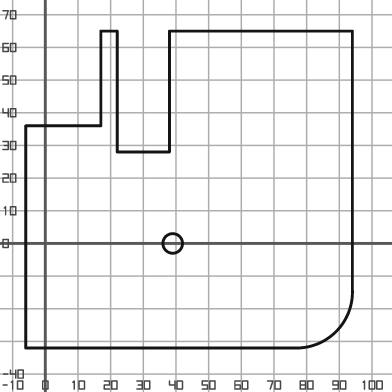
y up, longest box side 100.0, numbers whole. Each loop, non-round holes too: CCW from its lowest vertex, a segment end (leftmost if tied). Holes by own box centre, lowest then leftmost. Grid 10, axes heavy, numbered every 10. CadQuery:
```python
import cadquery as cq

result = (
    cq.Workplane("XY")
    .moveTo(-6.0, -32.0)
    .lineTo(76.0, -32.0)
    .threePointArc((89.0, -27.0), (94.0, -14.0))
    .lineTo(94.0, 65.0)
    .lineTo(38.0, 65.0)
    .lineTo(38.0, 28.0)
    .lineTo(22.0, 28.0)
    .lineTo(22.0, 65.0)
    .lineTo(17.0, 65.0)
    .lineTo(17.0, 36.0)
    .lineTo(-6.0, 36.0)
    .close()
    .moveTo(39.0, 0.0)
    .circle(3.0)
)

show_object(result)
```